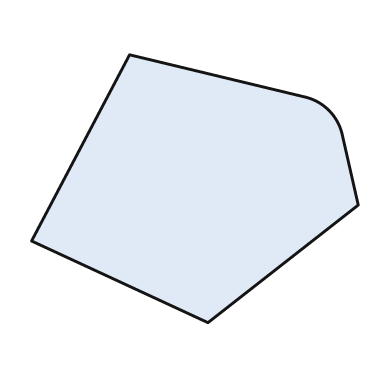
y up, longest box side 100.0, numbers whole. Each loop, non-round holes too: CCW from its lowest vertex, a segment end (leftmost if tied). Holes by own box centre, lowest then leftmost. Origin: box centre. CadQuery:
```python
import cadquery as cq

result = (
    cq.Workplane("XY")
    .moveTo(4.0, -41.0)
    .lineTo(50.0, -5.0)
    .lineTo(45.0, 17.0)
    .threePointArc((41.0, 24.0), (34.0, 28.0))
    .lineTo(-20.0, 41.0)
    .lineTo(-50.0, -16.0)
    .close()
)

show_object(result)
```